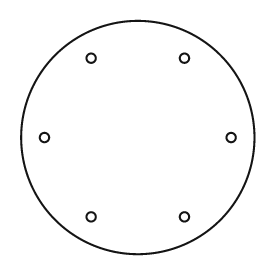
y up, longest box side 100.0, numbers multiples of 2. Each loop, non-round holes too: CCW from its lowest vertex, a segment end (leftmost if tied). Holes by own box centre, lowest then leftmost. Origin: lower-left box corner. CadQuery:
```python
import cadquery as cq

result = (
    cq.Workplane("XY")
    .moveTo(50.0, 50.0)
    .circle(50.0)
    .moveTo(30.0, 16.0)
    .circle(2.0)
    .moveTo(70.0, 16.0)
    .circle(2.0)
    .moveTo(10.0, 50.0)
    .circle(2.0)
    .moveTo(90.0, 50.0)
    .circle(2.0)
    .moveTo(30.0, 84.0)
    .circle(2.0)
    .moveTo(70.0, 84.0)
    .circle(2.0)
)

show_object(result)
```